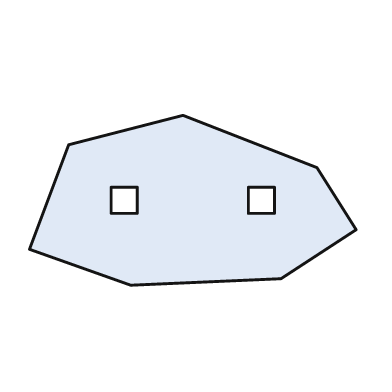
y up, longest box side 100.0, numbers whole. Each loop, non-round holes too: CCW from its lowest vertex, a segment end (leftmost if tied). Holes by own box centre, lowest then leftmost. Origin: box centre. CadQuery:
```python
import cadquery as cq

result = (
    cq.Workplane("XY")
    .moveTo(-19.0, -26.0)
    .lineTo(27.0, -24.0)
    .lineTo(50.0, -9.0)
    .lineTo(38.0, 10.0)
    .lineTo(-3.0, 26.0)
    .lineTo(-38.0, 17.0)
    .lineTo(-50.0, -15.0)
    .close()
    .moveTo(-25.0, -4.0)
    .lineTo(-17.0, -4.0)
    .lineTo(-17.0, 4.0)
    .lineTo(-25.0, 4.0)
    .close()
    .moveTo(17.0, -4.0)
    .lineTo(25.0, -4.0)
    .lineTo(25.0, 4.0)
    .lineTo(17.0, 4.0)
    .close()
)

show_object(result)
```